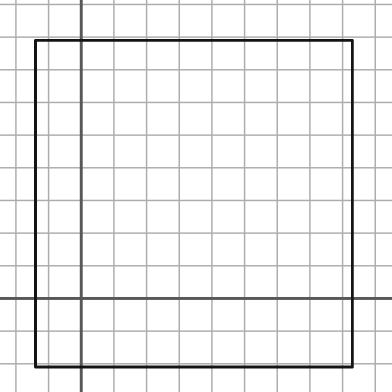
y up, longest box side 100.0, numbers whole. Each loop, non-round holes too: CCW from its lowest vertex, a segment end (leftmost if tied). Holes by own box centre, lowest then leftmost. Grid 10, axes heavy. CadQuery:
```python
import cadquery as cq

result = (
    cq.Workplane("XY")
    .moveTo(-14.0, -21.0)
    .lineTo(83.0, -21.0)
    .lineTo(83.0, 79.0)
    .lineTo(-14.0, 79.0)
    .close()
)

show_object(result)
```